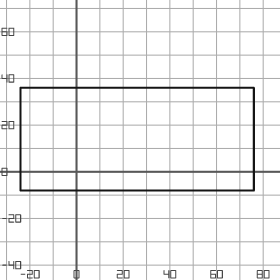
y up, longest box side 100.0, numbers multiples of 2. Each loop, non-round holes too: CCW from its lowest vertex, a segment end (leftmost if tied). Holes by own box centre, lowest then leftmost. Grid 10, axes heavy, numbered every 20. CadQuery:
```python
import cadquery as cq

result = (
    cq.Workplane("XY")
    .moveTo(-24.0, -8.0)
    .lineTo(76.0, -8.0)
    .lineTo(76.0, 36.0)
    .lineTo(-24.0, 36.0)
    .close()
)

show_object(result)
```